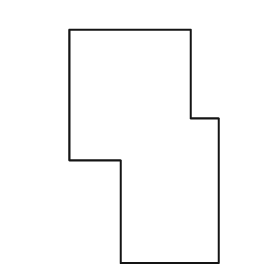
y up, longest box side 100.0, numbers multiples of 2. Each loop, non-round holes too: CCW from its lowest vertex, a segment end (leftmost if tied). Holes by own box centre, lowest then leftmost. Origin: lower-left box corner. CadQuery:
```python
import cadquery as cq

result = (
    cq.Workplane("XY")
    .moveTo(22.0, 0.0)
    .lineTo(64.0, 0.0)
    .lineTo(64.0, 62.0)
    .lineTo(52.0, 62.0)
    .lineTo(52.0, 100.0)
    .lineTo(0.0, 100.0)
    .lineTo(0.0, 44.0)
    .lineTo(22.0, 44.0)
    .close()
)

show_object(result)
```